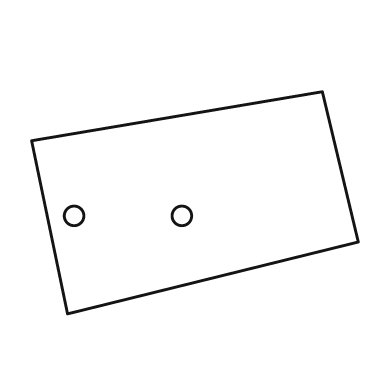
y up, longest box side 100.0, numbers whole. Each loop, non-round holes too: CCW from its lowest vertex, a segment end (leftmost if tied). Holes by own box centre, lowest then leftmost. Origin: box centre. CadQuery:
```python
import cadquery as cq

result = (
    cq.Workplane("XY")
    .moveTo(-39.0, -34.0)
    .lineTo(50.0, -12.0)
    .lineTo(39.0, 34.0)
    .lineTo(-50.0, 19.0)
    .close()
    .moveTo(-37.0, -4.0)
    .circle(3.0)
    .moveTo(-4.0, -4.0)
    .circle(3.0)
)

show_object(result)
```